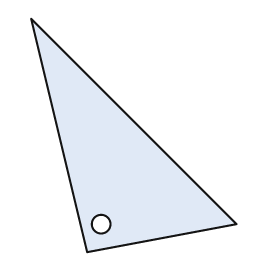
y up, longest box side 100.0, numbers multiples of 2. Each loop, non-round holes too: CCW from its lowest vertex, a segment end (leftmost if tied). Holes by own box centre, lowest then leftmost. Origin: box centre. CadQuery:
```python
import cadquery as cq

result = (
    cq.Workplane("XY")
    .moveTo(-20.0, -50.0)
    .lineTo(44.0, -38.0)
    .lineTo(-44.0, 50.0)
    .close()
    .moveTo(-14.0, -38.0)
    .circle(4.0)
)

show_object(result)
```